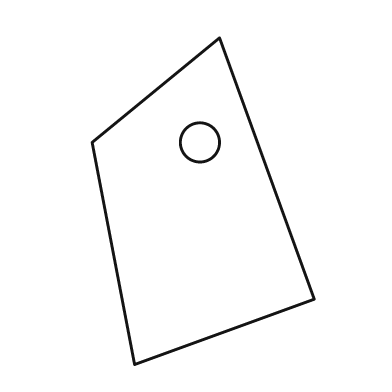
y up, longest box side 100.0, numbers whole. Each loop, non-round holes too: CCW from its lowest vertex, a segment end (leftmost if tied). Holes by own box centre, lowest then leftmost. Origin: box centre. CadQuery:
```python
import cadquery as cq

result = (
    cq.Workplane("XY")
    .moveTo(-21.0, -50.0)
    .lineTo(34.0, -30.0)
    .lineTo(5.0, 50.0)
    .lineTo(-34.0, 18.0)
    .close()
    .moveTo(-1.0, 18.0)
    .circle(6.0)
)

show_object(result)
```